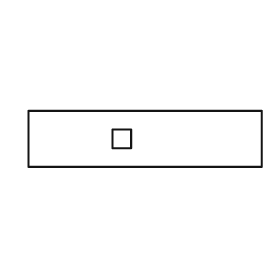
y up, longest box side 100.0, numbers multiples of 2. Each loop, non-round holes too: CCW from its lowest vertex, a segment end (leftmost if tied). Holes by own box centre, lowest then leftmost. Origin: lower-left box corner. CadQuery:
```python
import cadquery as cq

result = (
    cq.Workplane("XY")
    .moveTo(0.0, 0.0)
    .lineTo(100.0, 0.0)
    .lineTo(100.0, 24.0)
    .lineTo(0.0, 24.0)
    .close()
    .moveTo(36.0, 8.0)
    .lineTo(44.0, 8.0)
    .lineTo(44.0, 16.0)
    .lineTo(36.0, 16.0)
    .close()
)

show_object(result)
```